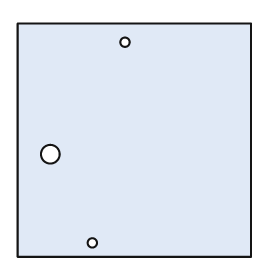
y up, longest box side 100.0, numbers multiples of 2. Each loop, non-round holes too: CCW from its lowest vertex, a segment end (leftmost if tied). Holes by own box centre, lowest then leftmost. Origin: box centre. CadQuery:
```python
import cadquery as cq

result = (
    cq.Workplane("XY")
    .moveTo(-50.0, -50.0)
    .lineTo(50.0, -50.0)
    .lineTo(50.0, 50.0)
    .lineTo(-50.0, 50.0)
    .close()
    .moveTo(-18.0, -44.0)
    .circle(2.0)
    .moveTo(-36.0, -6.0)
    .circle(4.0)
    .moveTo(-4.0, 42.0)
    .circle(2.0)
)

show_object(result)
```